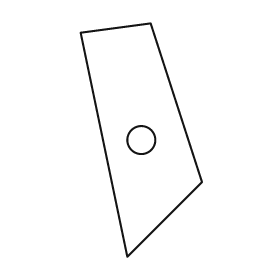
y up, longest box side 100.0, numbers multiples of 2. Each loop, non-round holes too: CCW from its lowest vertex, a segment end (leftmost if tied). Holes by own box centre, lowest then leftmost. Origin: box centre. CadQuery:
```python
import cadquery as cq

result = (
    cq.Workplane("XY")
    .moveTo(-6.0, -50.0)
    .lineTo(26.0, -18.0)
    .lineTo(4.0, 50.0)
    .lineTo(-26.0, 46.0)
    .close()
    .moveTo(0.0, 0.0)
    .circle(6.0)
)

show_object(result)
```